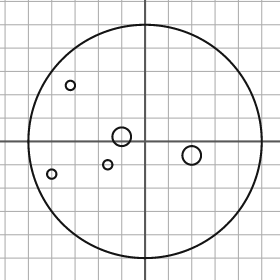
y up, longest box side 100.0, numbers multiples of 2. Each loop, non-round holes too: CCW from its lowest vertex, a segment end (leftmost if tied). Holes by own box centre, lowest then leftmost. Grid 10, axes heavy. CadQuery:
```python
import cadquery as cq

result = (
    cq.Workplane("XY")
    .moveTo(0.0, 0.0)
    .circle(50.0)
    .moveTo(-40.0, -14.0)
    .circle(2.0)
    .moveTo(-16.0, -10.0)
    .circle(2.0)
    .moveTo(20.0, -6.0)
    .circle(4.0)
    .moveTo(-10.0, 2.0)
    .circle(4.0)
    .moveTo(-32.0, 24.0)
    .circle(2.0)
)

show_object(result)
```